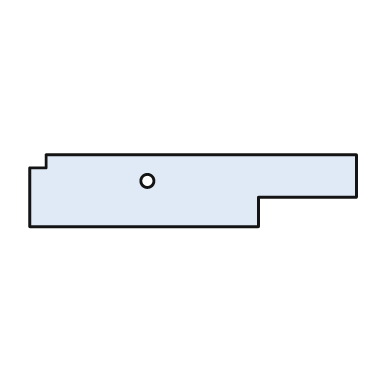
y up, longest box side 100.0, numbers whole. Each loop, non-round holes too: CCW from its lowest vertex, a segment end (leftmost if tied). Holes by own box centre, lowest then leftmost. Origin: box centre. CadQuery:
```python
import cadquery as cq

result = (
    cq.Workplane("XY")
    .moveTo(-50.0, -11.0)
    .lineTo(20.0, -11.0)
    .lineTo(20.0, -2.0)
    .lineTo(50.0, -2.0)
    .lineTo(50.0, 11.0)
    .lineTo(-45.0, 11.0)
    .lineTo(-45.0, 7.0)
    .lineTo(-50.0, 7.0)
    .close()
    .moveTo(-14.0, 3.0)
    .circle(2.0)
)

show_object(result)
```